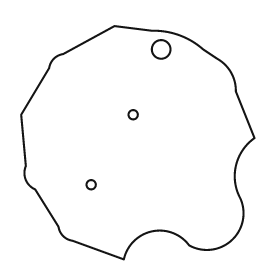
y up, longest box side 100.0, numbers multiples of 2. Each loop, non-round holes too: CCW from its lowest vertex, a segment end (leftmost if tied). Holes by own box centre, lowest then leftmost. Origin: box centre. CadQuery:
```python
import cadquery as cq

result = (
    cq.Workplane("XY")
    .moveTo(-6.0, -50.0)
    .threePointArc((6.0, -38.0), (22.0, -44.0))
    .threePointArc((40.0, -42.0), (44.0, -24.0))
    .threePointArc((42.0, -10.0), (50.0, 2.0))
    .lineTo(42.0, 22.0)
    .threePointArc((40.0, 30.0), (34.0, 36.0))
    .lineTo(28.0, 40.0)
    .threePointArc((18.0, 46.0), (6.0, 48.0))
    .lineTo(-10.0, 50.0)
    .lineTo(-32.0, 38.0)
    .threePointArc((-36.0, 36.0), (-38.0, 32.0))
    .lineTo(-50.0, 12.0)
    .lineTo(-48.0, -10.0)
    .threePointArc((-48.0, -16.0), (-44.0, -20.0))
    .lineTo(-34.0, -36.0)
    .threePointArc((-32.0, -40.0), (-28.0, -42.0))
    .close()
    .moveTo(-20.0, -18.0)
    .circle(2.0)
    .moveTo(-2.0, 12.0)
    .circle(2.0)
    .moveTo(10.0, 40.0)
    .circle(4.0)
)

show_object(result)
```